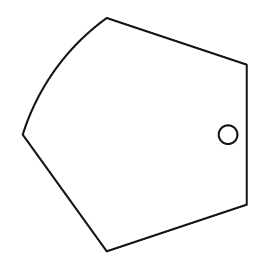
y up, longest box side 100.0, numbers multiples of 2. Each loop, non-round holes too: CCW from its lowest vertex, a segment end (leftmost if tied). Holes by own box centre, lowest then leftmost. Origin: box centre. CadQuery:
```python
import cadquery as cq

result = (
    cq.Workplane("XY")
    .moveTo(-12.0, -50.0)
    .lineTo(48.0, -30.0)
    .lineTo(48.0, 30.0)
    .lineTo(-12.0, 50.0)
    .threePointArc((-34.0, 28.0), (-48.0, 0.0))
    .close()
    .moveTo(40.0, 0.0)
    .circle(4.0)
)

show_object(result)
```